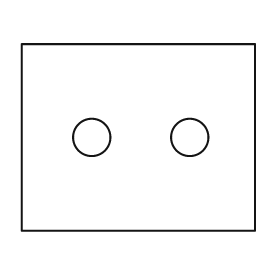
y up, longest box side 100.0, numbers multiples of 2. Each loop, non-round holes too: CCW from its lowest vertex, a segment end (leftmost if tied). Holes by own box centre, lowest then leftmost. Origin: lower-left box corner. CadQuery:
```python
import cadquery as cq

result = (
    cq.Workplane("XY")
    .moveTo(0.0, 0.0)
    .lineTo(100.0, 0.0)
    .lineTo(100.0, 80.0)
    .lineTo(0.0, 80.0)
    .close()
    .moveTo(30.0, 40.0)
    .circle(8.0)
    .moveTo(72.0, 40.0)
    .circle(8.0)
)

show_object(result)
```